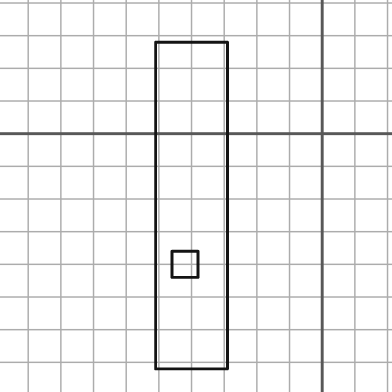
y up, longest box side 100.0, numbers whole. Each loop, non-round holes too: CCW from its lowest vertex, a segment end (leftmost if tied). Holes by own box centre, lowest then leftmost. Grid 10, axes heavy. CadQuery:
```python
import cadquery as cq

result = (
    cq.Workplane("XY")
    .moveTo(-51.0, -72.0)
    .lineTo(-29.0, -72.0)
    .lineTo(-29.0, 28.0)
    .lineTo(-51.0, 28.0)
    .close()
    .moveTo(-46.0, -44.0)
    .lineTo(-38.0, -44.0)
    .lineTo(-38.0, -36.0)
    .lineTo(-46.0, -36.0)
    .close()
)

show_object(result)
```